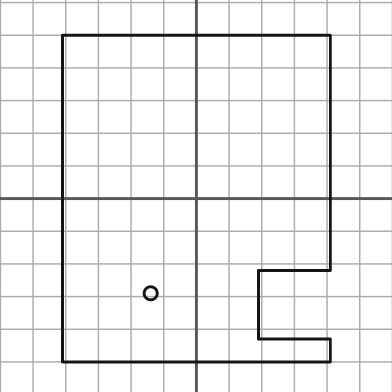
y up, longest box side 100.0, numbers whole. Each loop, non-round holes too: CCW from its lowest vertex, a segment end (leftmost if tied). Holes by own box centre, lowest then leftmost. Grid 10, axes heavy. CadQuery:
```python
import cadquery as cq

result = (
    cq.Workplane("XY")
    .moveTo(-41.0, -50.0)
    .lineTo(41.0, -50.0)
    .lineTo(41.0, -43.0)
    .lineTo(19.0, -43.0)
    .lineTo(19.0, -22.0)
    .lineTo(41.0, -22.0)
    .lineTo(41.0, 50.0)
    .lineTo(-41.0, 50.0)
    .close()
    .moveTo(-14.0, -29.0)
    .circle(2.0)
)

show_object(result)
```